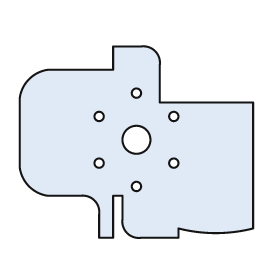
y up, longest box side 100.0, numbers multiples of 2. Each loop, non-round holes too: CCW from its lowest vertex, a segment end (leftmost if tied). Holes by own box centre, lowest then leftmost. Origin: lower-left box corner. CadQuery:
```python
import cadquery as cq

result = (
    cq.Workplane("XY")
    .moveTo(34.0, 0.0)
    .lineTo(40.0, 0.0)
    .lineTo(40.0, 18.0)
    .lineTo(44.0, 18.0)
    .lineTo(44.0, 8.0)
    .threePointArc((46.0, 2.0), (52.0, 0.0))
    .lineTo(68.0, 0.0)
    .lineTo(68.0, 4.0)
    .threePointArc((84.0, 2.0), (100.0, 4.0))
    .lineTo(100.0, 58.0)
    .lineTo(60.0, 58.0)
    .lineTo(60.0, 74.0)
    .threePointArc((58.0, 80.0), (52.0, 82.0))
    .lineTo(40.0, 82.0)
    .lineTo(40.0, 72.0)
    .lineTo(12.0, 72.0)
    .threePointArc((4.0, 68.0), (0.0, 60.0))
    .lineTo(0.0, 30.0)
    .threePointArc((4.0, 22.0), (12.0, 18.0))
    .lineTo(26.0, 18.0)
    .threePointArc((32.0, 16.0), (34.0, 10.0))
    .close()
    .moveTo(50.0, 22.0)
    .circle(2.0)
    .moveTo(34.0, 32.0)
    .circle(2.0)
    .moveTo(66.0, 32.0)
    .circle(2.0)
    .moveTo(50.0, 42.0)
    .circle(6.0)
    .moveTo(34.0, 52.0)
    .circle(2.0)
    .moveTo(66.0, 52.0)
    .circle(2.0)
    .moveTo(50.0, 62.0)
    .circle(2.0)
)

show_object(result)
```